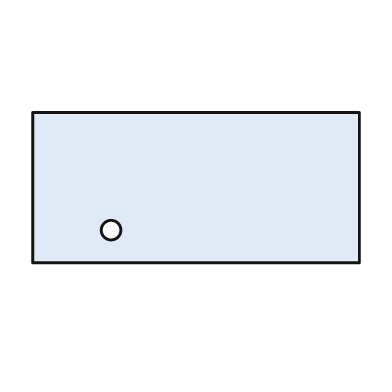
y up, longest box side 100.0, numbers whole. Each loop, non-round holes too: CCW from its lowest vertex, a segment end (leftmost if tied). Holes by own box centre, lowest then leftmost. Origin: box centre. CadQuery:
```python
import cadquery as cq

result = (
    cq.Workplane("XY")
    .moveTo(-50.0, -23.0)
    .lineTo(50.0, -23.0)
    .lineTo(50.0, 23.0)
    .lineTo(-50.0, 23.0)
    .close()
    .moveTo(-26.0, -13.0)
    .circle(3.0)
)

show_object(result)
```